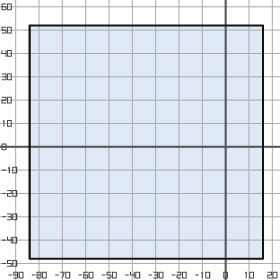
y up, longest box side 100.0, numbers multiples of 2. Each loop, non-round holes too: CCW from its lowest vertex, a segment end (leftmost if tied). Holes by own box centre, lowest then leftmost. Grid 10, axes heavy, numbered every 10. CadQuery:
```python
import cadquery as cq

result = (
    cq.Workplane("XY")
    .moveTo(-84.0, -48.0)
    .lineTo(16.0, -48.0)
    .lineTo(16.0, 52.0)
    .lineTo(-84.0, 52.0)
    .close()
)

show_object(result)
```